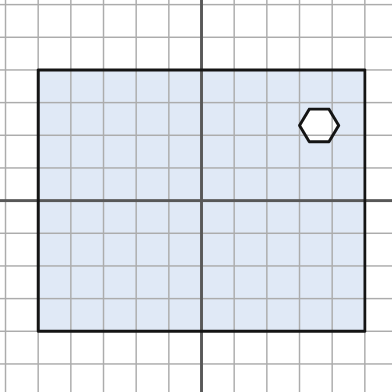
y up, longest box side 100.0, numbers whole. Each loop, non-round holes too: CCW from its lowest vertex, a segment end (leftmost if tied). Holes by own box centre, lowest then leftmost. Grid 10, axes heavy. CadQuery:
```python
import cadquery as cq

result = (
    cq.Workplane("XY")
    .moveTo(-50.0, -40.0)
    .lineTo(50.0, -40.0)
    .lineTo(50.0, 40.0)
    .lineTo(-50.0, 40.0)
    .close()
    .moveTo(33.0, 18.0)
    .lineTo(39.0, 18.0)
    .lineTo(42.0, 23.0)
    .lineTo(39.0, 28.0)
    .lineTo(33.0, 28.0)
    .lineTo(30.0, 23.0)
    .close()
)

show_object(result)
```